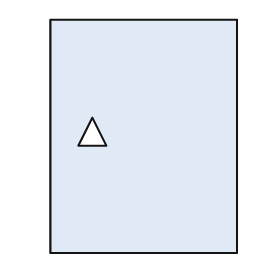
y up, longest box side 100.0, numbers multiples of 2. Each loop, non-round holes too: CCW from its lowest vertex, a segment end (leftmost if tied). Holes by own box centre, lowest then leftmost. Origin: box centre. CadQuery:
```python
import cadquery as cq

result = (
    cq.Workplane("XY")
    .moveTo(-40.0, -50.0)
    .lineTo(40.0, -50.0)
    .lineTo(40.0, 50.0)
    .lineTo(-40.0, 50.0)
    .close()
    .moveTo(-28.0, -4.0)
    .lineTo(-16.0, -4.0)
    .lineTo(-22.0, 8.0)
    .close()
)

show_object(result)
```